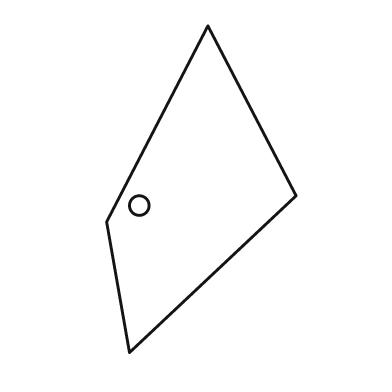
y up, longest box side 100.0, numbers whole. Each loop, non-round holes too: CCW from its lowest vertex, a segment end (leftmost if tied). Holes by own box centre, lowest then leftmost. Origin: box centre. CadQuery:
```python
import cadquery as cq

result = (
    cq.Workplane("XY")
    .moveTo(-22.0, -50.0)
    .lineTo(29.0, -2.0)
    .lineTo(2.0, 50.0)
    .lineTo(-29.0, -10.0)
    .close()
    .moveTo(-19.0, -5.0)
    .circle(3.0)
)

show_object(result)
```